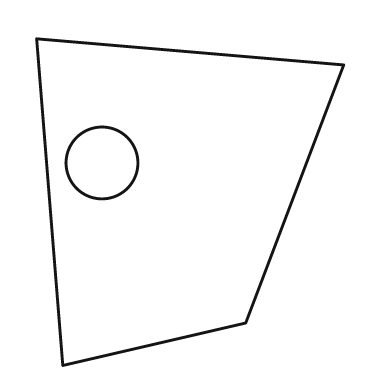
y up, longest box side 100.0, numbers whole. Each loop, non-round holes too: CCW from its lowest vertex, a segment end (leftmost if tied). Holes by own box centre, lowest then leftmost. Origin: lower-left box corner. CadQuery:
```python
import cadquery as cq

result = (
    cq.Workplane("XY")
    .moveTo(8.0, 0.0)
    .lineTo(64.0, 13.0)
    .lineTo(94.0, 92.0)
    .lineTo(0.0, 100.0)
    .close()
    .moveTo(20.0, 62.0)
    .circle(11.0)
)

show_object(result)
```